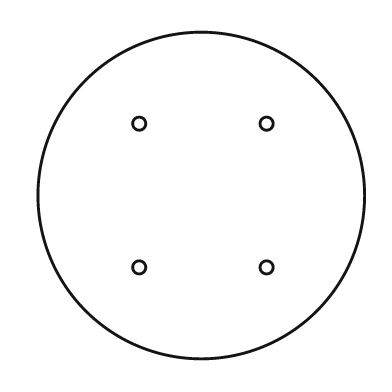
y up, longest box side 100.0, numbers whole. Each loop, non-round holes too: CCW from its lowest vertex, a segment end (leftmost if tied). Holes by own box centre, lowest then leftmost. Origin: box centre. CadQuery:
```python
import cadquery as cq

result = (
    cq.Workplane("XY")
    .moveTo(0.0, 0.0)
    .circle(50.0)
    .moveTo(-19.0, -22.0)
    .circle(2.0)
    .moveTo(20.0, -22.0)
    .circle(2.0)
    .moveTo(-19.0, 22.0)
    .circle(2.0)
    .moveTo(20.0, 22.0)
    .circle(2.0)
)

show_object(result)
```